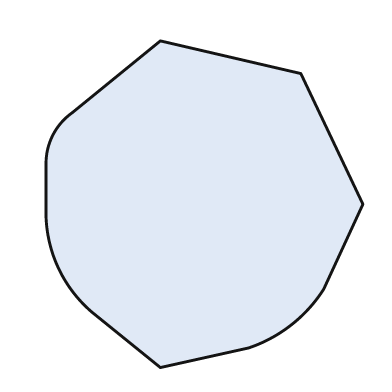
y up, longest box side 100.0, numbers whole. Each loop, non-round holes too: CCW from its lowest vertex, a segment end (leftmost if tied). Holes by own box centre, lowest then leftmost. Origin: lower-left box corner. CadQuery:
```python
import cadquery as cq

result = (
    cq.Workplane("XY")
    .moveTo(35.0, 0.0)
    .lineTo(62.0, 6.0)
    .threePointArc((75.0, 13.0), (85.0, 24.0))
    .lineTo(97.0, 50.0)
    .lineTo(78.0, 90.0)
    .lineTo(35.0, 100.0)
    .lineTo(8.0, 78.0)
    .threePointArc((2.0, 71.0), (0.0, 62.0))
    .lineTo(0.0, 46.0)
    .threePointArc((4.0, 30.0), (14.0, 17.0))
    .close()
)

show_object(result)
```